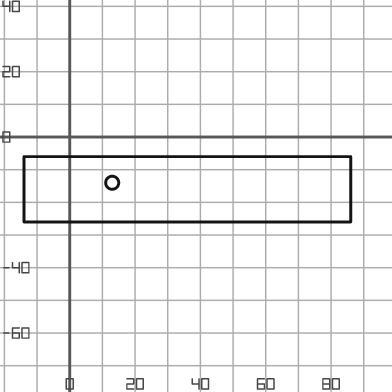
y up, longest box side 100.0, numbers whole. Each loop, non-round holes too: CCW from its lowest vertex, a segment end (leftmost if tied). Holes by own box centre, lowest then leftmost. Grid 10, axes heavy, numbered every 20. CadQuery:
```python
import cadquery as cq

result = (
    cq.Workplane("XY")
    .moveTo(-14.0, -26.0)
    .lineTo(86.0, -26.0)
    .lineTo(86.0, -6.0)
    .lineTo(-14.0, -6.0)
    .close()
    .moveTo(13.0, -14.0)
    .circle(2.0)
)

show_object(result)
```